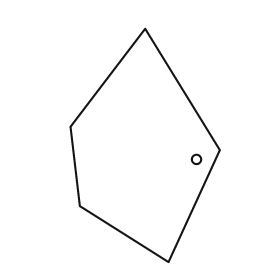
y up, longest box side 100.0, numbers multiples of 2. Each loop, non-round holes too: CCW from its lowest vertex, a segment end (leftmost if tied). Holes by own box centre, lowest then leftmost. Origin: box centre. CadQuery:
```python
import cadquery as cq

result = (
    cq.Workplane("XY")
    .moveTo(10.0, -50.0)
    .lineTo(32.0, -2.0)
    .lineTo(0.0, 50.0)
    .lineTo(-32.0, 8.0)
    .lineTo(-28.0, -26.0)
    .close()
    .moveTo(22.0, -6.0)
    .circle(2.0)
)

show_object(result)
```